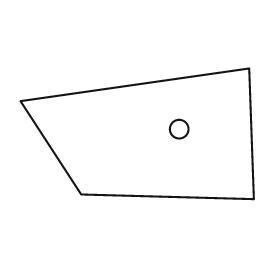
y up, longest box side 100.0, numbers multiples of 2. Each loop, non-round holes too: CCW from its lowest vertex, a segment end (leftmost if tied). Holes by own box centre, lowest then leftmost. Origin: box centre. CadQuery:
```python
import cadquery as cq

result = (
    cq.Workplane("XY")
    .moveTo(50.0, -28.0)
    .lineTo(48.0, 28.0)
    .lineTo(-50.0, 14.0)
    .lineTo(-24.0, -26.0)
    .close()
    .moveTo(18.0, 2.0)
    .circle(4.0)
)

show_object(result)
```